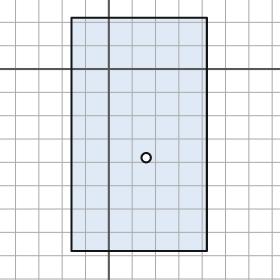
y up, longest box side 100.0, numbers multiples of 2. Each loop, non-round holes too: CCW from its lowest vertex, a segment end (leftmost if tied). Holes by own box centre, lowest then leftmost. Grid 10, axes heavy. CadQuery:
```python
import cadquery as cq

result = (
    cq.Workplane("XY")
    .moveTo(-16.0, -78.0)
    .lineTo(42.0, -78.0)
    .lineTo(42.0, 22.0)
    .lineTo(-16.0, 22.0)
    .close()
    .moveTo(16.0, -38.0)
    .circle(2.0)
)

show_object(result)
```